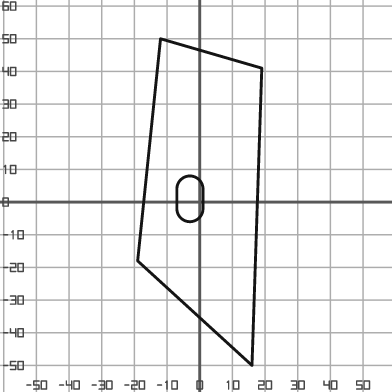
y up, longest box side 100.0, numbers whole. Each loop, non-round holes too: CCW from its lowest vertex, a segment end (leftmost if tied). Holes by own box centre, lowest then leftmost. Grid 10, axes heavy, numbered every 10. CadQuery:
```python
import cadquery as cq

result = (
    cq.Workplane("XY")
    .moveTo(16.0, -50.0)
    .lineTo(19.0, 41.0)
    .lineTo(-12.0, 50.0)
    .lineTo(-19.0, -18.0)
    .close()
    .moveTo(-7.0, -2.0)
    .threePointArc((-3.0, -6.0), (1.0, -2.0))
    .lineTo(1.0, 4.0)
    .threePointArc((-3.0, 8.0), (-7.0, 4.0))
    .close()
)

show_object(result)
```